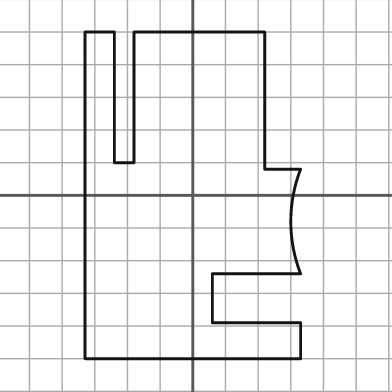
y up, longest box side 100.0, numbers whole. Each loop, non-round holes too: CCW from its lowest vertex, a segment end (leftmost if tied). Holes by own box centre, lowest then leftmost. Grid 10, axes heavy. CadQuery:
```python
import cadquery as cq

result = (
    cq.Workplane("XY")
    .moveTo(-33.0, -50.0)
    .lineTo(33.0, -50.0)
    .lineTo(33.0, -39.0)
    .lineTo(6.0, -39.0)
    .lineTo(6.0, -24.0)
    .lineTo(33.0, -24.0)
    .threePointArc((30.0, -8.0), (33.0, 8.0))
    .lineTo(22.0, 8.0)
    .lineTo(22.0, 50.0)
    .lineTo(-18.0, 50.0)
    .lineTo(-18.0, 10.0)
    .lineTo(-24.0, 10.0)
    .lineTo(-24.0, 50.0)
    .lineTo(-33.0, 50.0)
    .close()
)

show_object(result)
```